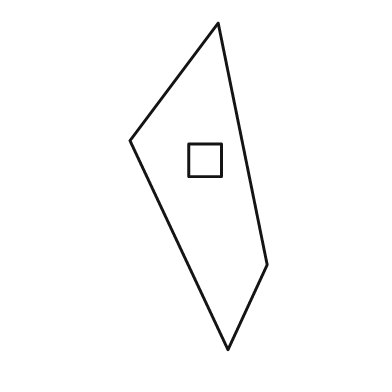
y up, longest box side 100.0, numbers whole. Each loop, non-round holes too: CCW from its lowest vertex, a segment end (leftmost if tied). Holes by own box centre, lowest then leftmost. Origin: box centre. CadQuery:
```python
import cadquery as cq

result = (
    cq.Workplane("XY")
    .moveTo(9.0, -50.0)
    .lineTo(21.0, -24.0)
    .lineTo(6.0, 50.0)
    .lineTo(-21.0, 14.0)
    .close()
    .moveTo(-3.0, 3.0)
    .lineTo(7.0, 3.0)
    .lineTo(7.0, 13.0)
    .lineTo(-3.0, 13.0)
    .close()
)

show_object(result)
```